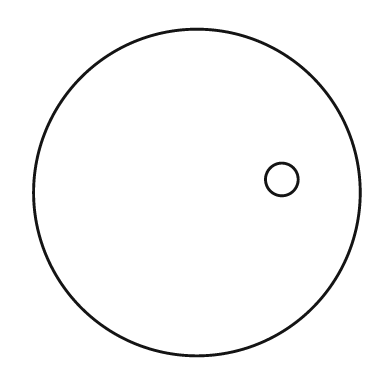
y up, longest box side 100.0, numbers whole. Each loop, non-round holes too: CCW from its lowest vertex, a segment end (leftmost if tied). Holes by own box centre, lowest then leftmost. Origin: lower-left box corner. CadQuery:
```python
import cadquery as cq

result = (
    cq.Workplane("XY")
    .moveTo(50.0, 50.0)
    .circle(50.0)
    .moveTo(76.0, 54.0)
    .circle(5.0)
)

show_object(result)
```